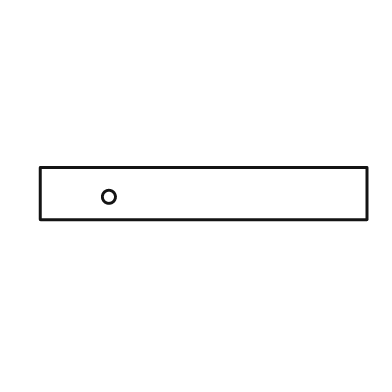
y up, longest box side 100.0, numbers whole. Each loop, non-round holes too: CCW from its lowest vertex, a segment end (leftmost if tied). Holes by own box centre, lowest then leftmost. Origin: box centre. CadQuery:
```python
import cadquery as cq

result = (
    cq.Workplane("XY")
    .moveTo(-50.0, -8.0)
    .lineTo(50.0, -8.0)
    .lineTo(50.0, 8.0)
    .lineTo(-50.0, 8.0)
    .close()
    .moveTo(-29.0, -1.0)
    .circle(2.0)
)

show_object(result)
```